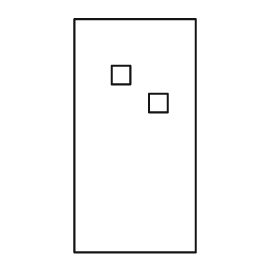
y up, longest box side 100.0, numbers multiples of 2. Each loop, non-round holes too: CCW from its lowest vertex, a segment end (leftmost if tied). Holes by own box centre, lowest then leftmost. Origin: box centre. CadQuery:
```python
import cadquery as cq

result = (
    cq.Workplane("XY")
    .moveTo(-26.0, -50.0)
    .lineTo(26.0, -50.0)
    .lineTo(26.0, 50.0)
    .lineTo(-26.0, 50.0)
    .close()
    .moveTo(6.0, 10.0)
    .lineTo(14.0, 10.0)
    .lineTo(14.0, 18.0)
    .lineTo(6.0, 18.0)
    .close()
    .moveTo(-10.0, 22.0)
    .lineTo(-2.0, 22.0)
    .lineTo(-2.0, 30.0)
    .lineTo(-10.0, 30.0)
    .close()
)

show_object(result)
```